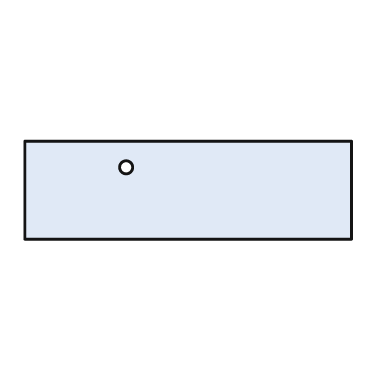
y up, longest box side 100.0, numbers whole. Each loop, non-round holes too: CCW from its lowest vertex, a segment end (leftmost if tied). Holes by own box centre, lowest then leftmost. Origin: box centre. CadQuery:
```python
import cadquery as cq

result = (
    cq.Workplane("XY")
    .moveTo(-50.0, -15.0)
    .lineTo(50.0, -15.0)
    .lineTo(50.0, 15.0)
    .lineTo(-50.0, 15.0)
    .close()
    .moveTo(-19.0, 7.0)
    .circle(2.0)
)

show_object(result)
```